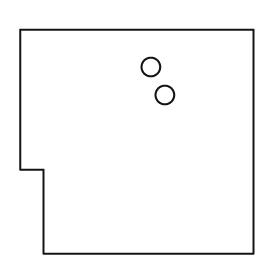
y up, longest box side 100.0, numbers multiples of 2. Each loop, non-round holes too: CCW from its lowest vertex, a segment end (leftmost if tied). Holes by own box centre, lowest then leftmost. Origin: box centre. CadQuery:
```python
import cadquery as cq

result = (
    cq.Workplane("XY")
    .moveTo(-40.0, -48.0)
    .lineTo(50.0, -48.0)
    .lineTo(50.0, 48.0)
    .lineTo(-50.0, 48.0)
    .lineTo(-50.0, -12.0)
    .lineTo(-40.0, -12.0)
    .close()
    .moveTo(12.0, 20.0)
    .circle(4.0)
    .moveTo(6.0, 32.0)
    .circle(4.0)
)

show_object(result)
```